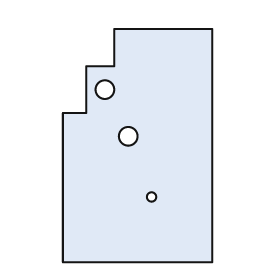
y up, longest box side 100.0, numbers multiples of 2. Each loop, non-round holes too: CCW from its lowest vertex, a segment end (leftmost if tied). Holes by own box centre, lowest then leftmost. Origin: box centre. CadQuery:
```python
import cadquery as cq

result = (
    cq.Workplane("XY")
    .moveTo(-32.0, -50.0)
    .lineTo(32.0, -50.0)
    .lineTo(32.0, 50.0)
    .lineTo(-10.0, 50.0)
    .lineTo(-10.0, 34.0)
    .lineTo(-22.0, 34.0)
    .lineTo(-22.0, 14.0)
    .lineTo(-32.0, 14.0)
    .close()
    .moveTo(6.0, -22.0)
    .circle(2.0)
    .moveTo(-4.0, 4.0)
    .circle(4.0)
    .moveTo(-14.0, 24.0)
    .circle(4.0)
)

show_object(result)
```